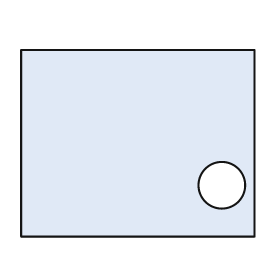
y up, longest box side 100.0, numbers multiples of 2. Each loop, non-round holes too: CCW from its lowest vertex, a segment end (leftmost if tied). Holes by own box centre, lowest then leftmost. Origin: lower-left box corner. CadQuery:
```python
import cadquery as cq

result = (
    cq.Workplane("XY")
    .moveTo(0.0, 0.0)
    .lineTo(100.0, 0.0)
    .lineTo(100.0, 80.0)
    .lineTo(0.0, 80.0)
    .close()
    .moveTo(86.0, 22.0)
    .circle(10.0)
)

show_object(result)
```